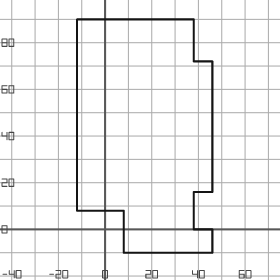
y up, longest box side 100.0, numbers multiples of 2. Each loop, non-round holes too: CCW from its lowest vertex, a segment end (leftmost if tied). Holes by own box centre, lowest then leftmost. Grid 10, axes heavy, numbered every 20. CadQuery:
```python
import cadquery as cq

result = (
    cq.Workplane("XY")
    .moveTo(8.0, -10.0)
    .lineTo(46.0, -10.0)
    .lineTo(46.0, 0.0)
    .lineTo(38.0, 0.0)
    .lineTo(38.0, 16.0)
    .lineTo(46.0, 16.0)
    .lineTo(46.0, 72.0)
    .lineTo(38.0, 72.0)
    .lineTo(38.0, 90.0)
    .lineTo(-12.0, 90.0)
    .lineTo(-12.0, 8.0)
    .lineTo(8.0, 8.0)
    .close()
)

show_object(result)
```